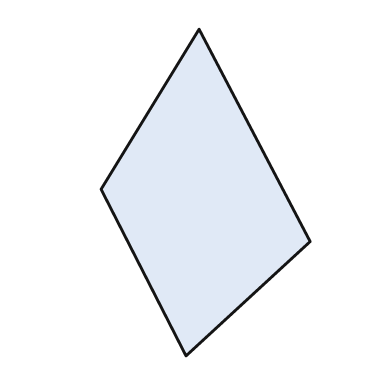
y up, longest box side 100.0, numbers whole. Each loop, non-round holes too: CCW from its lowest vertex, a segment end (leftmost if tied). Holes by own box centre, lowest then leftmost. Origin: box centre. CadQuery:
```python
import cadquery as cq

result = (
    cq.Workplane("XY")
    .moveTo(-6.0, -50.0)
    .lineTo(32.0, -15.0)
    .lineTo(-2.0, 50.0)
    .lineTo(-32.0, 1.0)
    .close()
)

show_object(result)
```